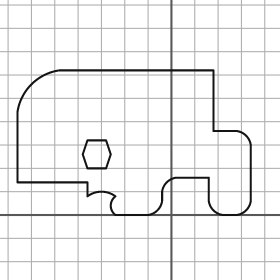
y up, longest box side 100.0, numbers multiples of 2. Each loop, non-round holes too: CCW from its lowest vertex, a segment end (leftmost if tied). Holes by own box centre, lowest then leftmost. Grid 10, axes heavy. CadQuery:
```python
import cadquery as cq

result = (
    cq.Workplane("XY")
    .moveTo(-24.0, 0.0)
    .lineTo(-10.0, 0.0)
    .threePointArc((-6.0, 2.0), (-4.0, 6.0))
    .lineTo(-4.0, 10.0)
    .threePointArc((-2.0, 14.0), (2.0, 16.0))
    .lineTo(16.0, 16.0)
    .lineTo(16.0, 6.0)
    .threePointArc((18.0, 2.0), (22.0, 0.0))
    .lineTo(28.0, 0.0)
    .threePointArc((32.0, 2.0), (34.0, 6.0))
    .lineTo(34.0, 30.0)
    .threePointArc((32.0, 34.0), (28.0, 36.0))
    .lineTo(18.0, 36.0)
    .lineTo(18.0, 62.0)
    .lineTo(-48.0, 62.0)
    .threePointArc((-60.0, 56.0), (-66.0, 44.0))
    .lineTo(-66.0, 14.0)
    .lineTo(-36.0, 14.0)
    .lineTo(-36.0, 8.0)
    .threePointArc((-30.0, 10.0), (-24.0, 8.0))
    .threePointArc((-26.0, 4.0), (-24.0, 0.0))
    .close()
    .moveTo(-36.0, 20.0)
    .lineTo(-28.0, 20.0)
    .lineTo(-26.0, 26.0)
    .lineTo(-28.0, 32.0)
    .lineTo(-36.0, 32.0)
    .lineTo(-38.0, 26.0)
    .close()
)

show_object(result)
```